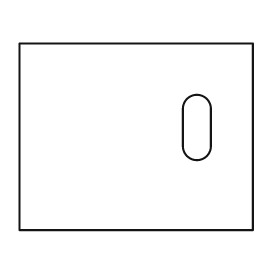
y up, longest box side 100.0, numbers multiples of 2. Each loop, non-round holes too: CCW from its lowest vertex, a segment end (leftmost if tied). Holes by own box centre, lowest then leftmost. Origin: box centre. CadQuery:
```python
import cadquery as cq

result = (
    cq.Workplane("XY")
    .moveTo(-50.0, -40.0)
    .lineTo(50.0, -40.0)
    .lineTo(50.0, 40.0)
    .lineTo(-50.0, 40.0)
    .close()
    .moveTo(20.0, -4.0)
    .threePointArc((26.0, -10.0), (32.0, -4.0))
    .lineTo(32.0, 12.0)
    .threePointArc((26.0, 18.0), (20.0, 12.0))
    .close()
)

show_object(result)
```